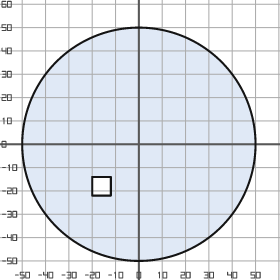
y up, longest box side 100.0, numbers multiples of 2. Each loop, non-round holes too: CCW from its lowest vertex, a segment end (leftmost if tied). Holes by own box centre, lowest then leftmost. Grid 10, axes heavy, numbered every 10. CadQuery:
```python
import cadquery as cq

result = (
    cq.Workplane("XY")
    .moveTo(0.0, 0.0)
    .circle(50.0)
    .moveTo(-20.0, -22.0)
    .lineTo(-12.0, -22.0)
    .lineTo(-12.0, -14.0)
    .lineTo(-20.0, -14.0)
    .close()
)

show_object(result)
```